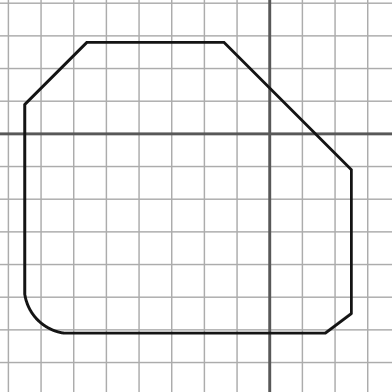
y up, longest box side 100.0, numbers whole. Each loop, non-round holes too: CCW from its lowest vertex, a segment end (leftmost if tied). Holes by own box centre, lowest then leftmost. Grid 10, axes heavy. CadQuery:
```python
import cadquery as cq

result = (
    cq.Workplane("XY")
    .moveTo(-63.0, -61.0)
    .lineTo(17.0, -61.0)
    .lineTo(25.0, -55.0)
    .lineTo(25.0, -11.0)
    .lineTo(-14.0, 28.0)
    .lineTo(-56.0, 28.0)
    .lineTo(-75.0, 9.0)
    .lineTo(-75.0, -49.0)
    .threePointArc((-71.0, -57.0), (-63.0, -61.0))
    .close()
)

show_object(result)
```